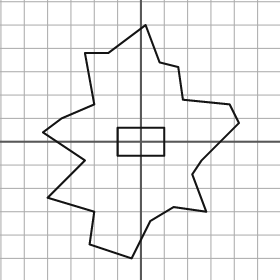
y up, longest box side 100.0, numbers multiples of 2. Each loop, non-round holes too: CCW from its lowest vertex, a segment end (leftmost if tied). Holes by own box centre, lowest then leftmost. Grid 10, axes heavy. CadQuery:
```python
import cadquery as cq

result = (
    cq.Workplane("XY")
    .moveTo(-4.0, -50.0)
    .lineTo(4.0, -34.0)
    .lineTo(14.0, -28.0)
    .lineTo(28.0, -30.0)
    .lineTo(22.0, -14.0)
    .lineTo(26.0, -8.0)
    .lineTo(42.0, 8.0)
    .lineTo(38.0, 16.0)
    .lineTo(18.0, 18.0)
    .lineTo(16.0, 32.0)
    .lineTo(8.0, 34.0)
    .lineTo(2.0, 50.0)
    .lineTo(-14.0, 38.0)
    .lineTo(-24.0, 38.0)
    .lineTo(-20.0, 16.0)
    .lineTo(-34.0, 10.0)
    .lineTo(-42.0, 4.0)
    .lineTo(-24.0, -8.0)
    .lineTo(-40.0, -24.0)
    .lineTo(-20.0, -30.0)
    .lineTo(-22.0, -44.0)
    .close()
    .moveTo(-10.0, -6.0)
    .lineTo(10.0, -6.0)
    .lineTo(10.0, 6.0)
    .lineTo(-10.0, 6.0)
    .close()
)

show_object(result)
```